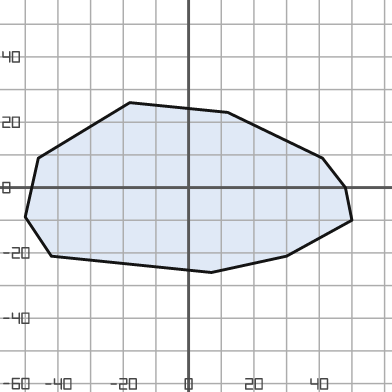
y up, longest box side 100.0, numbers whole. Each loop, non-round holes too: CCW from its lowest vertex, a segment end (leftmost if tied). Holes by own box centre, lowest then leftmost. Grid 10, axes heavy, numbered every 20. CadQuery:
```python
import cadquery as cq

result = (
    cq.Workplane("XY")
    .moveTo(7.0, -26.0)
    .lineTo(30.0, -21.0)
    .lineTo(50.0, -10.0)
    .lineTo(48.0, 0.0)
    .lineTo(41.0, 9.0)
    .lineTo(12.0, 23.0)
    .lineTo(-18.0, 26.0)
    .lineTo(-46.0, 9.0)
    .lineTo(-50.0, -9.0)
    .lineTo(-42.0, -21.0)
    .close()
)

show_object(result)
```